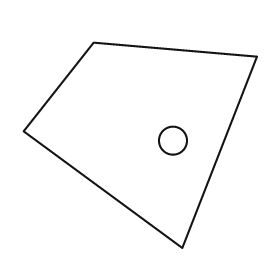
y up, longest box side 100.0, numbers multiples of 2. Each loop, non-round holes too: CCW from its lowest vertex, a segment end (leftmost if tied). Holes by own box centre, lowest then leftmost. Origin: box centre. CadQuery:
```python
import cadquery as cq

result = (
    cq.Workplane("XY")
    .moveTo(18.0, -44.0)
    .lineTo(50.0, 38.0)
    .lineTo(-20.0, 44.0)
    .lineTo(-50.0, 6.0)
    .close()
    .moveTo(14.0, 2.0)
    .circle(6.0)
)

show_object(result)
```